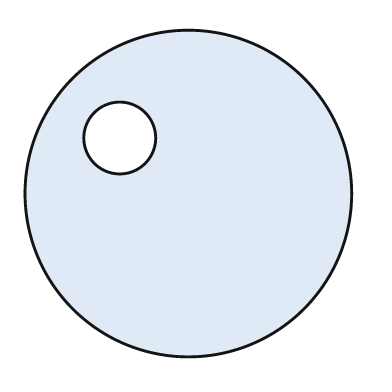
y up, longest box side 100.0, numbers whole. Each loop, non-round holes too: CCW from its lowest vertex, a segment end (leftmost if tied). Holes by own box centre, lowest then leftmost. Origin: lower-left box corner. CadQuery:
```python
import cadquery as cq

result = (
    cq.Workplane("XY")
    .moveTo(50.0, 50.0)
    .circle(50.0)
    .moveTo(29.0, 67.0)
    .circle(11.0)
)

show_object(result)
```